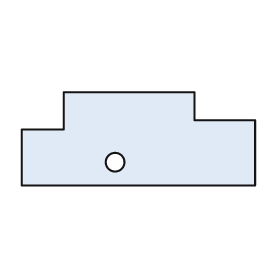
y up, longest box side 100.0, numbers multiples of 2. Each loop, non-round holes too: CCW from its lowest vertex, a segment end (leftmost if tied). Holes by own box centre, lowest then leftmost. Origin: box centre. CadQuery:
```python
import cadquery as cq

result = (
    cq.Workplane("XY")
    .moveTo(-50.0, -20.0)
    .lineTo(50.0, -20.0)
    .lineTo(50.0, 8.0)
    .lineTo(24.0, 8.0)
    .lineTo(24.0, 20.0)
    .lineTo(-32.0, 20.0)
    .lineTo(-32.0, 4.0)
    .lineTo(-50.0, 4.0)
    .close()
    .moveTo(-10.0, -10.0)
    .circle(4.0)
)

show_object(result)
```